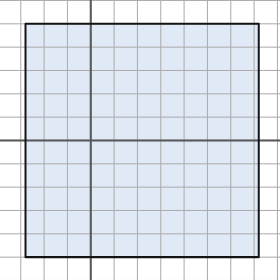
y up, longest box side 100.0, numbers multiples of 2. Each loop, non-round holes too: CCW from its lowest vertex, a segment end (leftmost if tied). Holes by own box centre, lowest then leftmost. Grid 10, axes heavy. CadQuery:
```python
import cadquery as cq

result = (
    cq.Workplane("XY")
    .moveTo(-28.0, -50.0)
    .lineTo(72.0, -50.0)
    .lineTo(72.0, 50.0)
    .lineTo(-28.0, 50.0)
    .close()
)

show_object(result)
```